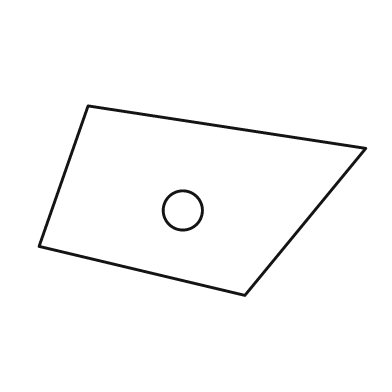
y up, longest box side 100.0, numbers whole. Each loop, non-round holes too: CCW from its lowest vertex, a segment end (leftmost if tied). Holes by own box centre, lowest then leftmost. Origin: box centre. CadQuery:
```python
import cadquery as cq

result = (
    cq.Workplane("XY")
    .moveTo(13.0, -29.0)
    .lineTo(50.0, 16.0)
    .lineTo(-35.0, 29.0)
    .lineTo(-50.0, -14.0)
    .close()
    .moveTo(-6.0, -3.0)
    .circle(6.0)
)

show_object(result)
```